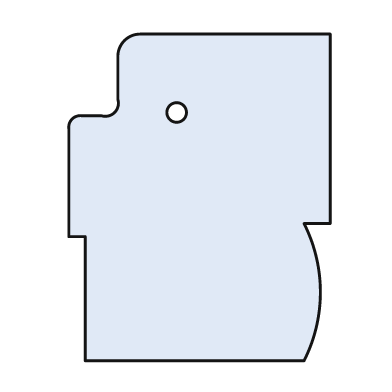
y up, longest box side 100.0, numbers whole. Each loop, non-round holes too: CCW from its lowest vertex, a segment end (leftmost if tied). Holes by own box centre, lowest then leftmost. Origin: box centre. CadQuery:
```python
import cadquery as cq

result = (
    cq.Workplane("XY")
    .moveTo(-35.0, -50.0)
    .lineTo(32.0, -50.0)
    .threePointArc((37.0, -29.0), (32.0, -8.0))
    .lineTo(40.0, -8.0)
    .lineTo(40.0, 50.0)
    .lineTo(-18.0, 50.0)
    .threePointArc((-23.0, 48.0), (-25.0, 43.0))
    .lineTo(-25.0, 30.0)
    .threePointArc((-26.0, 26.0), (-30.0, 25.0))
    .lineTo(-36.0, 25.0)
    .threePointArc((-39.0, 24.0), (-40.0, 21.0))
    .lineTo(-40.0, -12.0)
    .lineTo(-35.0, -12.0)
    .close()
    .moveTo(-7.0, 26.0)
    .circle(3.0)
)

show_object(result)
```